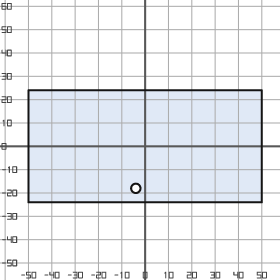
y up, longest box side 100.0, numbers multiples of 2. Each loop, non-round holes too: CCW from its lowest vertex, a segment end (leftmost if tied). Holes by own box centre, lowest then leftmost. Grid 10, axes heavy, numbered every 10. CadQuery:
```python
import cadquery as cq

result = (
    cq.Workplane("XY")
    .moveTo(-50.0, -24.0)
    .lineTo(50.0, -24.0)
    .lineTo(50.0, 24.0)
    .lineTo(-50.0, 24.0)
    .close()
    .moveTo(-4.0, -18.0)
    .circle(2.0)
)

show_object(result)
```